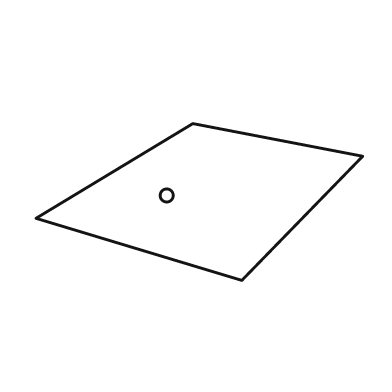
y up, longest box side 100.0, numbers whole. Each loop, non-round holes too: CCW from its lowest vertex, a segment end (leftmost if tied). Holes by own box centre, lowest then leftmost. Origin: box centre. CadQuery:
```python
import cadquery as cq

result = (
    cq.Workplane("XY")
    .moveTo(13.0, -24.0)
    .lineTo(50.0, 14.0)
    .lineTo(-2.0, 24.0)
    .lineTo(-50.0, -5.0)
    .close()
    .moveTo(-10.0, 2.0)
    .circle(2.0)
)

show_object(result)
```